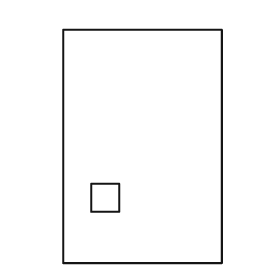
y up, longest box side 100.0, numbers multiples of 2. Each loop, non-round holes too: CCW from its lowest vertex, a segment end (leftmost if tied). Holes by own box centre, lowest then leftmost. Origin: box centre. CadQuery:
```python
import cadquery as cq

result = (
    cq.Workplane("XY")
    .moveTo(-34.0, -50.0)
    .lineTo(34.0, -50.0)
    .lineTo(34.0, 50.0)
    .lineTo(-34.0, 50.0)
    .close()
    .moveTo(-22.0, -28.0)
    .lineTo(-10.0, -28.0)
    .lineTo(-10.0, -16.0)
    .lineTo(-22.0, -16.0)
    .close()
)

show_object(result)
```